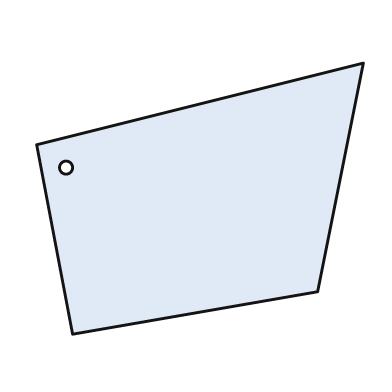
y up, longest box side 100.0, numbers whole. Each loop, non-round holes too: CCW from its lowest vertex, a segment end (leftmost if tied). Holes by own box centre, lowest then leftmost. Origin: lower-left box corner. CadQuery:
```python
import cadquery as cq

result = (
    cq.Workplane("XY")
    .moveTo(11.0, 0.0)
    .lineTo(86.0, 13.0)
    .lineTo(100.0, 83.0)
    .lineTo(0.0, 58.0)
    .close()
    .moveTo(9.0, 51.0)
    .circle(2.0)
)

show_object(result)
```